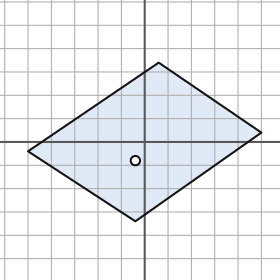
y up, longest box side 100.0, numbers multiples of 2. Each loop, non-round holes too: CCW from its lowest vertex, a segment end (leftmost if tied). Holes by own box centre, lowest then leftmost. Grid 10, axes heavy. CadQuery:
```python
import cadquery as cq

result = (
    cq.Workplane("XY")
    .moveTo(-4.0, -34.0)
    .lineTo(50.0, 4.0)
    .lineTo(6.0, 34.0)
    .lineTo(-50.0, -4.0)
    .close()
    .moveTo(-4.0, -8.0)
    .circle(2.0)
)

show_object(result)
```